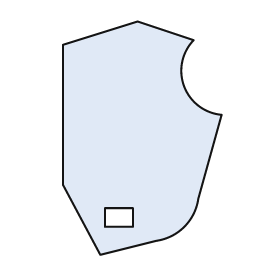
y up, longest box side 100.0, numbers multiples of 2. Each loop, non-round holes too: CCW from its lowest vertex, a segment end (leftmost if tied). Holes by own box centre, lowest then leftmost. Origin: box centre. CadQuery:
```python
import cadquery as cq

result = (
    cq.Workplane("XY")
    .moveTo(-18.0, -50.0)
    .lineTo(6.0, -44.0)
    .threePointArc((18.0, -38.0), (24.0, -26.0))
    .lineTo(34.0, 10.0)
    .threePointArc((18.0, 22.0), (22.0, 42.0))
    .lineTo(-2.0, 50.0)
    .lineTo(-34.0, 40.0)
    .lineTo(-34.0, -20.0)
    .close()
    .moveTo(-16.0, -38.0)
    .lineTo(-4.0, -38.0)
    .lineTo(-4.0, -30.0)
    .lineTo(-16.0, -30.0)
    .close()
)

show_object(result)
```